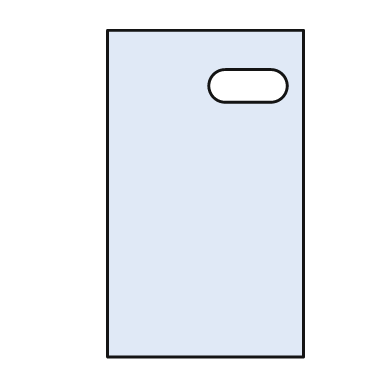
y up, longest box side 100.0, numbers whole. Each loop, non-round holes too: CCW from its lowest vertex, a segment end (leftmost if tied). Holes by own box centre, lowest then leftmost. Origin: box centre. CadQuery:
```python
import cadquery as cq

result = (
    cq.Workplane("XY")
    .moveTo(-30.0, -50.0)
    .lineTo(30.0, -50.0)
    .lineTo(30.0, 50.0)
    .lineTo(-30.0, 50.0)
    .close()
    .moveTo(6.0, 28.0)
    .lineTo(20.0, 28.0)
    .threePointArc((25.0, 33.0), (20.0, 38.0))
    .lineTo(6.0, 38.0)
    .threePointArc((1.0, 33.0), (6.0, 28.0))
    .close()
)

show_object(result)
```